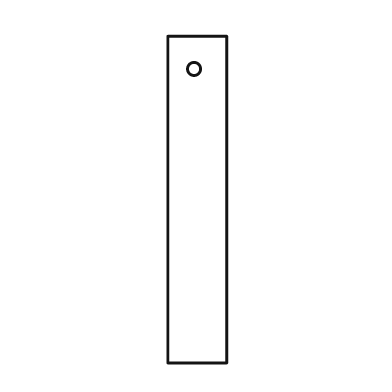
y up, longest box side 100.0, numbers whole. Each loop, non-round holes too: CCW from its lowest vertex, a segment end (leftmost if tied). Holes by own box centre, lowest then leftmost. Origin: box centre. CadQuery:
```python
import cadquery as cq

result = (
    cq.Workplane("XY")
    .moveTo(-9.0, -50.0)
    .lineTo(9.0, -50.0)
    .lineTo(9.0, 50.0)
    .lineTo(-9.0, 50.0)
    .close()
    .moveTo(-1.0, 40.0)
    .circle(2.0)
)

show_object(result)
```